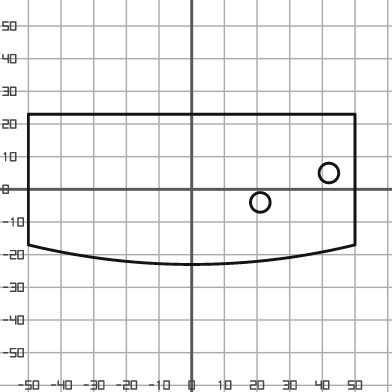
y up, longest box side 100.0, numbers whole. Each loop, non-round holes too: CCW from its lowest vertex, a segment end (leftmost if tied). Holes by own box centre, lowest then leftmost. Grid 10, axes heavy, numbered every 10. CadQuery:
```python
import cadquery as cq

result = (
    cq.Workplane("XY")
    .moveTo(-50.0, -17.0)
    .threePointArc((0.0, -23.0), (50.0, -17.0))
    .lineTo(50.0, 23.0)
    .lineTo(-50.0, 23.0)
    .close()
    .moveTo(21.0, -4.0)
    .circle(3.0)
    .moveTo(42.0, 5.0)
    .circle(3.0)
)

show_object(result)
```